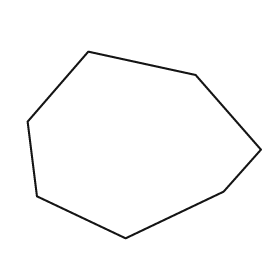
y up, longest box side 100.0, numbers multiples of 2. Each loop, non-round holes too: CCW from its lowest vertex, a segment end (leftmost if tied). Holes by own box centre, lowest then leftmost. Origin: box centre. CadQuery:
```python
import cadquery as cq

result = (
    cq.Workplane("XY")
    .moveTo(-8.0, -40.0)
    .lineTo(34.0, -20.0)
    .lineTo(50.0, -2.0)
    .lineTo(22.0, 30.0)
    .lineTo(-24.0, 40.0)
    .lineTo(-50.0, 10.0)
    .lineTo(-46.0, -22.0)
    .close()
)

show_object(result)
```